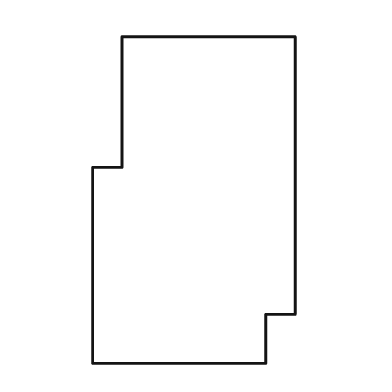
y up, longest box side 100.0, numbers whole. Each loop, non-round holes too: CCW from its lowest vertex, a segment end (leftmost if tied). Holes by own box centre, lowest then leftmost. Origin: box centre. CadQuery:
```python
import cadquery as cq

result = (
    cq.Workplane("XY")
    .moveTo(-31.0, -50.0)
    .lineTo(22.0, -50.0)
    .lineTo(22.0, -35.0)
    .lineTo(31.0, -35.0)
    .lineTo(31.0, 50.0)
    .lineTo(-22.0, 50.0)
    .lineTo(-22.0, 10.0)
    .lineTo(-31.0, 10.0)
    .close()
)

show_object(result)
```